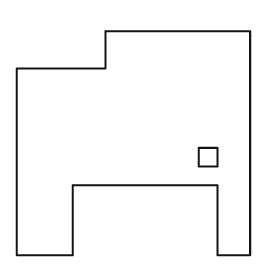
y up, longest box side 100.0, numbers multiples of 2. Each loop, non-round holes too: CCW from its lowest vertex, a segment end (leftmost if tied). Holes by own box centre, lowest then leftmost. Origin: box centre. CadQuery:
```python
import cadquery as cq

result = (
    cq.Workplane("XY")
    .moveTo(-50.0, -48.0)
    .lineTo(-26.0, -48.0)
    .lineTo(-26.0, -18.0)
    .lineTo(36.0, -18.0)
    .lineTo(36.0, -48.0)
    .lineTo(50.0, -48.0)
    .lineTo(50.0, 48.0)
    .lineTo(-12.0, 48.0)
    .lineTo(-12.0, 32.0)
    .lineTo(-50.0, 32.0)
    .close()
    .moveTo(28.0, -10.0)
    .lineTo(36.0, -10.0)
    .lineTo(36.0, -2.0)
    .lineTo(28.0, -2.0)
    .close()
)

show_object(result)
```